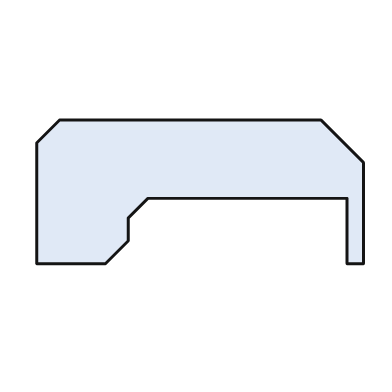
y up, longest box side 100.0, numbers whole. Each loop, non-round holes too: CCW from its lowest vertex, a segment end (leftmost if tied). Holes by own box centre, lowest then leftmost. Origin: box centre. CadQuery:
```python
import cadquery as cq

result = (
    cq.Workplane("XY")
    .moveTo(-50.0, -22.0)
    .lineTo(-29.0, -22.0)
    .lineTo(-22.0, -15.0)
    .lineTo(-22.0, -8.0)
    .lineTo(-16.0, -2.0)
    .lineTo(45.0, -2.0)
    .lineTo(45.0, -22.0)
    .lineTo(50.0, -22.0)
    .lineTo(50.0, 9.0)
    .lineTo(37.0, 22.0)
    .lineTo(-43.0, 22.0)
    .lineTo(-50.0, 15.0)
    .close()
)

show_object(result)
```